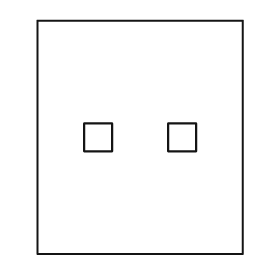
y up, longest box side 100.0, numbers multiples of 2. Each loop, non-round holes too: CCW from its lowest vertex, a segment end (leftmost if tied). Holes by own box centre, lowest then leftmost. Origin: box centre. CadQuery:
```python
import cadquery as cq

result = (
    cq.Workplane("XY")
    .moveTo(-44.0, -50.0)
    .lineTo(44.0, -50.0)
    .lineTo(44.0, 50.0)
    .lineTo(-44.0, 50.0)
    .close()
    .moveTo(-24.0, -6.0)
    .lineTo(-12.0, -6.0)
    .lineTo(-12.0, 6.0)
    .lineTo(-24.0, 6.0)
    .close()
    .moveTo(12.0, -6.0)
    .lineTo(24.0, -6.0)
    .lineTo(24.0, 6.0)
    .lineTo(12.0, 6.0)
    .close()
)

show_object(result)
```